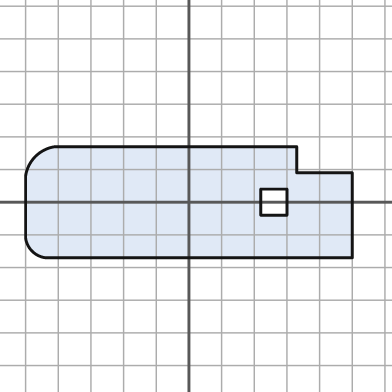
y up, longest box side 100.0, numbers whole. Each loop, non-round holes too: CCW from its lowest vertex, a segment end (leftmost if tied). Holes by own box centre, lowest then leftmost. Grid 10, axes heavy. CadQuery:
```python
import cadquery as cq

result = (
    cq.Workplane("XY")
    .moveTo(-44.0, -17.0)
    .lineTo(50.0, -17.0)
    .lineTo(50.0, 9.0)
    .lineTo(33.0, 9.0)
    .lineTo(33.0, 17.0)
    .lineTo(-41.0, 17.0)
    .threePointArc((-47.0, 14.0), (-50.0, 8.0))
    .lineTo(-50.0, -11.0)
    .threePointArc((-48.0, -15.0), (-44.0, -17.0))
    .close()
    .moveTo(22.0, -4.0)
    .lineTo(30.0, -4.0)
    .lineTo(30.0, 4.0)
    .lineTo(22.0, 4.0)
    .close()
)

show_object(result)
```